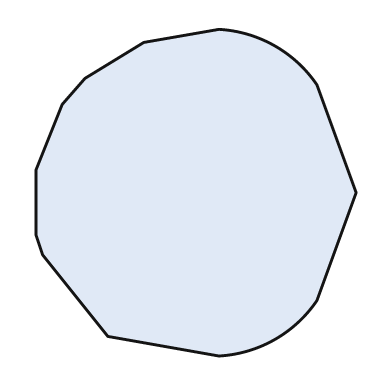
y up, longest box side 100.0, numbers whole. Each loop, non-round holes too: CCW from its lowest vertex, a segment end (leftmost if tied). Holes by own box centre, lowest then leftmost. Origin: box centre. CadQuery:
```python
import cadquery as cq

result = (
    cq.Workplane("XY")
    .moveTo(7.0, -50.0)
    .threePointArc((24.0, -45.0), (37.0, -33.0))
    .lineTo(49.0, 0.0)
    .lineTo(37.0, 33.0)
    .threePointArc((24.0, 45.0), (7.0, 50.0))
    .lineTo(-16.0, 46.0)
    .lineTo(-34.0, 35.0)
    .lineTo(-41.0, 27.0)
    .lineTo(-49.0, 7.0)
    .lineTo(-49.0, -13.0)
    .lineTo(-47.0, -19.0)
    .lineTo(-27.0, -44.0)
    .close()
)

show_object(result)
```